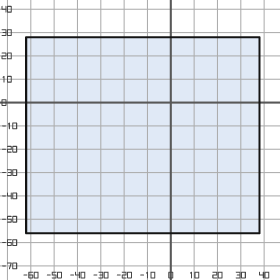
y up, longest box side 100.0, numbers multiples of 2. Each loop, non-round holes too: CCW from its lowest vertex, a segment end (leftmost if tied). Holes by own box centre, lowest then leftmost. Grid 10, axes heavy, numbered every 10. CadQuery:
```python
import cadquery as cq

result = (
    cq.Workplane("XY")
    .moveTo(-62.0, -56.0)
    .lineTo(38.0, -56.0)
    .lineTo(38.0, 28.0)
    .lineTo(-62.0, 28.0)
    .close()
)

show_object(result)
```